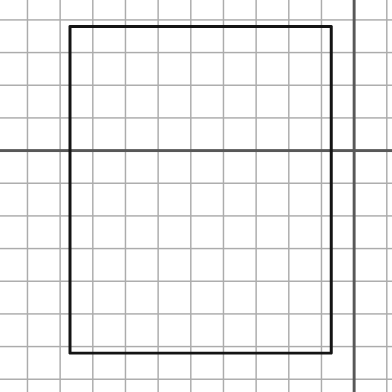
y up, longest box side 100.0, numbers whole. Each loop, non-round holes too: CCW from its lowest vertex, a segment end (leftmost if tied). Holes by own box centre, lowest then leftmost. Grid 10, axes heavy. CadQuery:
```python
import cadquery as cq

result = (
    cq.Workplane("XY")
    .moveTo(-87.0, -62.0)
    .lineTo(-7.0, -62.0)
    .lineTo(-7.0, 38.0)
    .lineTo(-87.0, 38.0)
    .close()
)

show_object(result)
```